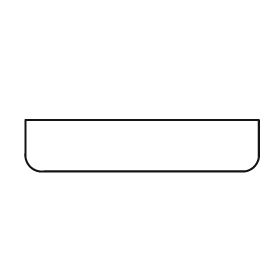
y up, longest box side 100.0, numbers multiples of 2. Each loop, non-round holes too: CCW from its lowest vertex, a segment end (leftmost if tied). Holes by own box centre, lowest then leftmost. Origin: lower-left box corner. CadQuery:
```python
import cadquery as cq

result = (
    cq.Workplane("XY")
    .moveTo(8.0, 0.0)
    .lineTo(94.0, 0.0)
    .threePointArc((98.0, 2.0), (100.0, 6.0))
    .lineTo(100.0, 22.0)
    .lineTo(0.0, 22.0)
    .lineTo(0.0, 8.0)
    .threePointArc((2.0, 2.0), (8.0, 0.0))
    .close()
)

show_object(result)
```